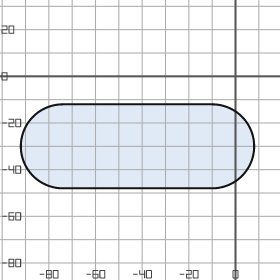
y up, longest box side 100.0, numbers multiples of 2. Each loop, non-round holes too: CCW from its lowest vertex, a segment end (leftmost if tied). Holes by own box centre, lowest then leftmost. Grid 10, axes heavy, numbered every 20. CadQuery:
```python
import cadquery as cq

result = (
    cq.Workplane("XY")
    .moveTo(-74.0, -48.0)
    .lineTo(-10.0, -48.0)
    .threePointArc((8.0, -30.0), (-10.0, -12.0))
    .lineTo(-74.0, -12.0)
    .threePointArc((-92.0, -30.0), (-74.0, -48.0))
    .close()
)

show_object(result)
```